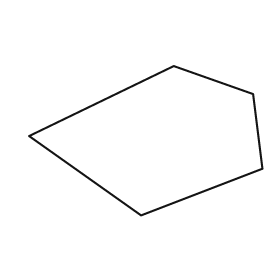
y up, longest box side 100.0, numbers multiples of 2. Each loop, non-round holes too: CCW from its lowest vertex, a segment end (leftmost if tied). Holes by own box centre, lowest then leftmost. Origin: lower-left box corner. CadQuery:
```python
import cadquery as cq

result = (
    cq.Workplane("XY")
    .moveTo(48.0, 0.0)
    .lineTo(100.0, 20.0)
    .lineTo(96.0, 52.0)
    .lineTo(62.0, 64.0)
    .lineTo(0.0, 34.0)
    .close()
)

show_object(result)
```